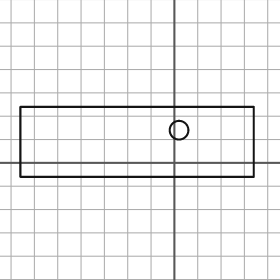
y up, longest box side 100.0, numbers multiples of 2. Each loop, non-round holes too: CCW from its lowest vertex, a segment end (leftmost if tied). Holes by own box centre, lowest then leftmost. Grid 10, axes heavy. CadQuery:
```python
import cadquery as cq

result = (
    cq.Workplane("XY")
    .moveTo(-66.0, -6.0)
    .lineTo(34.0, -6.0)
    .lineTo(34.0, 24.0)
    .lineTo(-66.0, 24.0)
    .close()
    .moveTo(2.0, 14.0)
    .circle(4.0)
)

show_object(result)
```